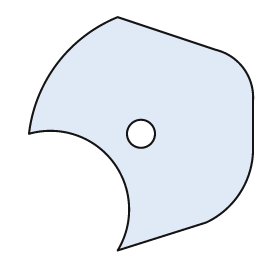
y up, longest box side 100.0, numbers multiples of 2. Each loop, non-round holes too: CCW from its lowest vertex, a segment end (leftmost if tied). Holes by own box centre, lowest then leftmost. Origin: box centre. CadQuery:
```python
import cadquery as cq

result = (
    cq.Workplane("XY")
    .moveTo(-10.0, -50.0)
    .lineTo(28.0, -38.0)
    .threePointArc((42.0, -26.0), (48.0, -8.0))
    .lineTo(48.0, 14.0)
    .threePointArc((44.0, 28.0), (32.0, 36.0))
    .lineTo(-10.0, 50.0)
    .threePointArc((-36.0, 30.0), (-48.0, 0.0))
    .threePointArc((-12.0, -12.0), (-10.0, -50.0))
    .close()
    .moveTo(0.0, 0.0)
    .circle(6.0)
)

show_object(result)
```